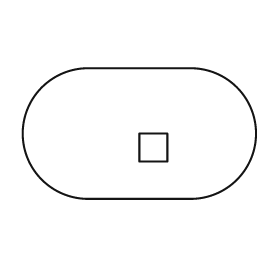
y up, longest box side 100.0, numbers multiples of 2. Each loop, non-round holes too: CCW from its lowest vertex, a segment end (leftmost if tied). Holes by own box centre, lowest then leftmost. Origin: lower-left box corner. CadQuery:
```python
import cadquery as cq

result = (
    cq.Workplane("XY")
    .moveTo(28.0, 0.0)
    .lineTo(72.0, 0.0)
    .threePointArc((100.0, 28.0), (72.0, 56.0))
    .lineTo(28.0, 56.0)
    .threePointArc((0.0, 28.0), (28.0, 0.0))
    .close()
    .moveTo(50.0, 16.0)
    .lineTo(62.0, 16.0)
    .lineTo(62.0, 28.0)
    .lineTo(50.0, 28.0)
    .close()
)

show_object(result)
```